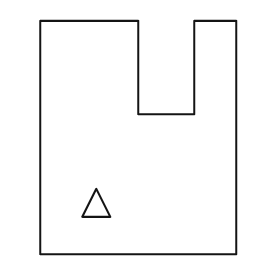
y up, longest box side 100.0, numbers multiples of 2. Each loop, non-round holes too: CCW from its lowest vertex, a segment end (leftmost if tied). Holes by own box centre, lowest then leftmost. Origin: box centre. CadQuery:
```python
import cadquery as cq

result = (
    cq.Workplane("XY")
    .moveTo(-42.0, -50.0)
    .lineTo(42.0, -50.0)
    .lineTo(42.0, 50.0)
    .lineTo(24.0, 50.0)
    .lineTo(24.0, 10.0)
    .lineTo(0.0, 10.0)
    .lineTo(0.0, 50.0)
    .lineTo(-42.0, 50.0)
    .close()
    .moveTo(-24.0, -34.0)
    .lineTo(-12.0, -34.0)
    .lineTo(-18.0, -22.0)
    .close()
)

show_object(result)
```